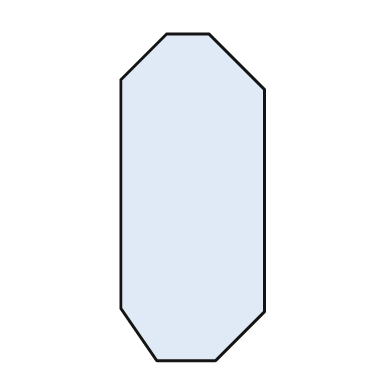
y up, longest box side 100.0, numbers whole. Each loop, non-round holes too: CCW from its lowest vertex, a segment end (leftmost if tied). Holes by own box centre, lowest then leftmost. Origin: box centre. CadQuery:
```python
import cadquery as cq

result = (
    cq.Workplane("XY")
    .moveTo(-11.0, -50.0)
    .lineTo(7.0, -50.0)
    .lineTo(22.0, -35.0)
    .lineTo(22.0, 33.0)
    .lineTo(5.0, 50.0)
    .lineTo(-8.0, 50.0)
    .lineTo(-22.0, 36.0)
    .lineTo(-22.0, -34.0)
    .close()
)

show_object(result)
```